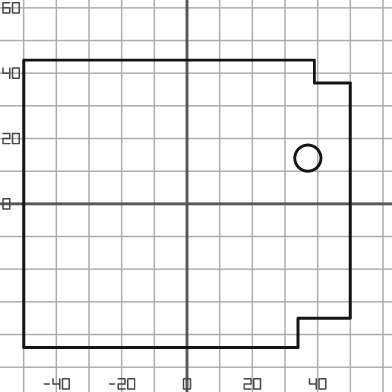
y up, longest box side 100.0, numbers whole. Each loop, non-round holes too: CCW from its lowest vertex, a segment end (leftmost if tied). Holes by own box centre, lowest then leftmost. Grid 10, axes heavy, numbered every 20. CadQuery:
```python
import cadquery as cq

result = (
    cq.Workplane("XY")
    .moveTo(-50.0, -44.0)
    .lineTo(34.0, -44.0)
    .lineTo(34.0, -35.0)
    .lineTo(50.0, -35.0)
    .lineTo(50.0, 37.0)
    .lineTo(39.0, 37.0)
    .lineTo(39.0, 44.0)
    .lineTo(-50.0, 44.0)
    .close()
    .moveTo(37.0, 14.0)
    .circle(4.0)
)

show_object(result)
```